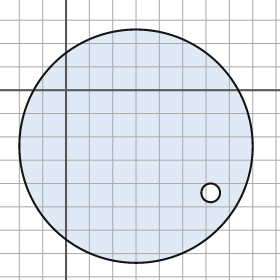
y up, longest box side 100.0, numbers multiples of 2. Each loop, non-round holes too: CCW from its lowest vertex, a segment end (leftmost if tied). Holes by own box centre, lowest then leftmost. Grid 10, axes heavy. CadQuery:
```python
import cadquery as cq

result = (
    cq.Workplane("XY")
    .moveTo(30.0, -24.0)
    .circle(50.0)
    .moveTo(62.0, -44.0)
    .circle(4.0)
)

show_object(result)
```